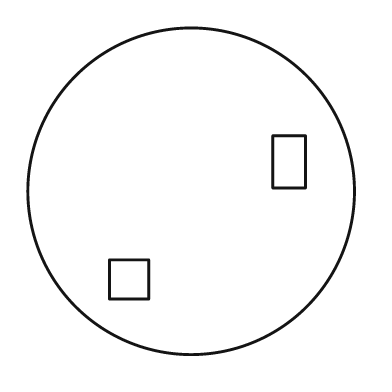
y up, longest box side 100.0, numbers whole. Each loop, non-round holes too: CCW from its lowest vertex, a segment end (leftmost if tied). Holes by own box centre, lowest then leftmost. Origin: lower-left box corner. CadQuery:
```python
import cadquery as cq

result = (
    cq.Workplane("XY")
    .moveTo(50.0, 50.0)
    .circle(50.0)
    .moveTo(25.0, 17.0)
    .lineTo(37.0, 17.0)
    .lineTo(37.0, 29.0)
    .lineTo(25.0, 29.0)
    .close()
    .moveTo(75.0, 51.0)
    .lineTo(85.0, 51.0)
    .lineTo(85.0, 67.0)
    .lineTo(75.0, 67.0)
    .close()
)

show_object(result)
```